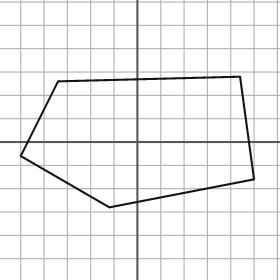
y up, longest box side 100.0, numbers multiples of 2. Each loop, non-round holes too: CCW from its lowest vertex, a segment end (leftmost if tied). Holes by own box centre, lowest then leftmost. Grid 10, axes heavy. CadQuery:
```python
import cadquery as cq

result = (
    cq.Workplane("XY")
    .moveTo(-12.0, -28.0)
    .lineTo(50.0, -16.0)
    .lineTo(44.0, 28.0)
    .lineTo(-34.0, 26.0)
    .lineTo(-50.0, -6.0)
    .close()
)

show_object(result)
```